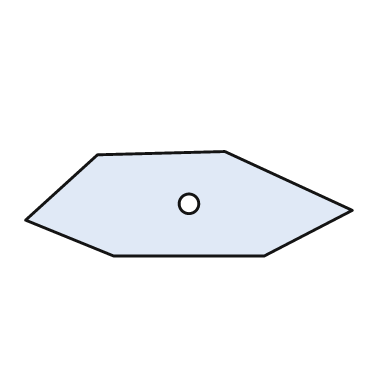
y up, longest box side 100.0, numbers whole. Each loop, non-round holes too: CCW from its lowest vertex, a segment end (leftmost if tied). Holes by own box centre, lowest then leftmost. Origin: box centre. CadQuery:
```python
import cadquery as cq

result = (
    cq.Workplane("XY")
    .moveTo(-23.0, -16.0)
    .lineTo(23.0, -16.0)
    .lineTo(50.0, -2.0)
    .lineTo(11.0, 16.0)
    .lineTo(-28.0, 15.0)
    .lineTo(-50.0, -5.0)
    .close()
    .moveTo(0.0, 0.0)
    .circle(3.0)
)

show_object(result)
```